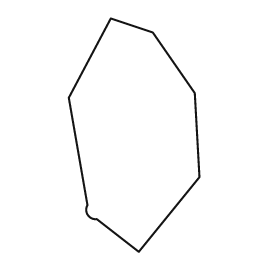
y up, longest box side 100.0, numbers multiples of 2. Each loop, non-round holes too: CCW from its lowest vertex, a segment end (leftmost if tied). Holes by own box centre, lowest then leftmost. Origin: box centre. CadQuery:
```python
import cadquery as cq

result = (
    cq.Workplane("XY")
    .moveTo(2.0, -50.0)
    .lineTo(28.0, -18.0)
    .lineTo(26.0, 18.0)
    .lineTo(8.0, 44.0)
    .lineTo(-10.0, 50.0)
    .lineTo(-28.0, 16.0)
    .lineTo(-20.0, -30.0)
    .threePointArc((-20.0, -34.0), (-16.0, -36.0))
    .close()
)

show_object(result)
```